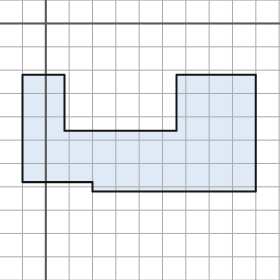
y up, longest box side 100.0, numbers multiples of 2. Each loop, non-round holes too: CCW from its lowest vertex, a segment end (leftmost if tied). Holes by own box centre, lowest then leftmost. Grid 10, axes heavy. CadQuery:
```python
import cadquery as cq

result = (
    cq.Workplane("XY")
    .moveTo(20.0, -72.0)
    .lineTo(90.0, -72.0)
    .lineTo(90.0, -22.0)
    .lineTo(56.0, -22.0)
    .lineTo(56.0, -46.0)
    .lineTo(8.0, -46.0)
    .lineTo(8.0, -22.0)
    .lineTo(-10.0, -22.0)
    .lineTo(-10.0, -68.0)
    .lineTo(20.0, -68.0)
    .close()
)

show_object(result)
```